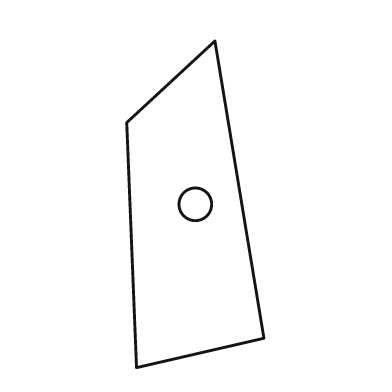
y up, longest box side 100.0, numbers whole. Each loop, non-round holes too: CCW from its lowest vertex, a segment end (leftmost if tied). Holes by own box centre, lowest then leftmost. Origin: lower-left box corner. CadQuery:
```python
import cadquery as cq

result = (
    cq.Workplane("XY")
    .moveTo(3.0, 0.0)
    .lineTo(42.0, 9.0)
    .lineTo(27.0, 100.0)
    .lineTo(0.0, 75.0)
    .close()
    .moveTo(21.0, 50.0)
    .circle(5.0)
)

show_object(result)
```